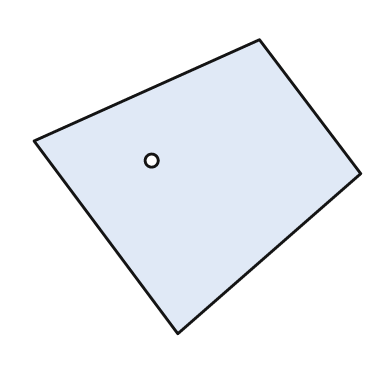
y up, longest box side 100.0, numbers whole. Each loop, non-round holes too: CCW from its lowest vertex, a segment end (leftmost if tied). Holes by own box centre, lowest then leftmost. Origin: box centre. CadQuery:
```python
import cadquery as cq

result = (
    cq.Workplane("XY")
    .moveTo(-6.0, -45.0)
    .lineTo(50.0, 4.0)
    .lineTo(19.0, 45.0)
    .lineTo(-50.0, 14.0)
    .close()
    .moveTo(-14.0, 8.0)
    .circle(2.0)
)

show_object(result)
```